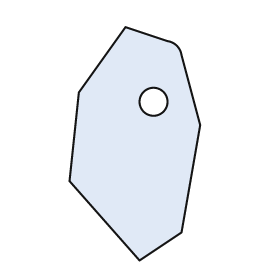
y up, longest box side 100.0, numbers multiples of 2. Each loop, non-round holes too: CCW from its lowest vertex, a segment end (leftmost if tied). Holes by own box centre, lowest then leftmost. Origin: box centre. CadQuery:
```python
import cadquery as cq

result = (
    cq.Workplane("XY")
    .moveTo(2.0, -50.0)
    .lineTo(20.0, -38.0)
    .lineTo(28.0, 8.0)
    .lineTo(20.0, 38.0)
    .threePointArc((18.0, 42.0), (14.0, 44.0))
    .lineTo(-4.0, 50.0)
    .lineTo(-24.0, 22.0)
    .lineTo(-28.0, -16.0)
    .close()
    .moveTo(8.0, 18.0)
    .circle(6.0)
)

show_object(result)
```